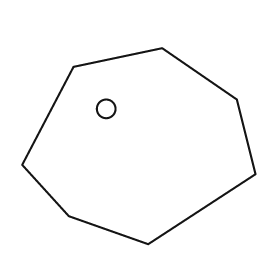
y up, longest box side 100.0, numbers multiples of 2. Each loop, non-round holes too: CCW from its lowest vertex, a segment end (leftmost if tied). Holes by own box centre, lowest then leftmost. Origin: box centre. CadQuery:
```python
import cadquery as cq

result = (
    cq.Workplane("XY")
    .moveTo(4.0, -42.0)
    .lineTo(50.0, -12.0)
    .lineTo(42.0, 20.0)
    .lineTo(10.0, 42.0)
    .lineTo(-28.0, 34.0)
    .lineTo(-50.0, -8.0)
    .lineTo(-30.0, -30.0)
    .close()
    .moveTo(-14.0, 16.0)
    .circle(4.0)
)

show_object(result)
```